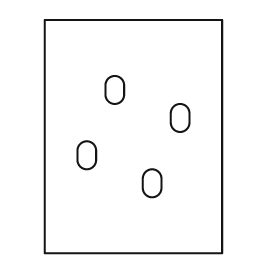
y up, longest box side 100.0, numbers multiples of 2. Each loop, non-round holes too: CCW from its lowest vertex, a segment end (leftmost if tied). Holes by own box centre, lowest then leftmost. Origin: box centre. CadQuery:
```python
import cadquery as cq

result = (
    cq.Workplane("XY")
    .moveTo(-38.0, -50.0)
    .lineTo(38.0, -50.0)
    .lineTo(38.0, 50.0)
    .lineTo(-38.0, 50.0)
    .close()
    .moveTo(4.0, -22.0)
    .threePointArc((8.0, -26.0), (12.0, -22.0))
    .lineTo(12.0, -18.0)
    .threePointArc((8.0, -14.0), (4.0, -18.0))
    .close()
    .moveTo(-24.0, -10.0)
    .threePointArc((-20.0, -14.0), (-16.0, -10.0))
    .lineTo(-16.0, -6.0)
    .threePointArc((-20.0, -2.0), (-24.0, -6.0))
    .close()
    .moveTo(16.0, 6.0)
    .threePointArc((20.0, 2.0), (24.0, 6.0))
    .lineTo(24.0, 10.0)
    .threePointArc((20.0, 14.0), (16.0, 10.0))
    .close()
    .moveTo(-12.0, 18.0)
    .threePointArc((-8.0, 14.0), (-4.0, 18.0))
    .lineTo(-4.0, 22.0)
    .threePointArc((-8.0, 26.0), (-12.0, 22.0))
    .close()
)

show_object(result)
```